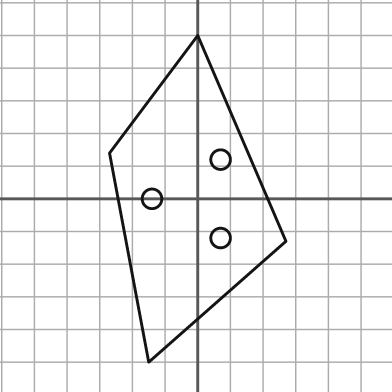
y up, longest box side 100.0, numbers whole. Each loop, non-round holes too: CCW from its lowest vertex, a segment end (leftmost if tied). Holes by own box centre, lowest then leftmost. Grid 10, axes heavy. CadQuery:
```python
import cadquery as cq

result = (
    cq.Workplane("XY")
    .moveTo(-15.0, -50.0)
    .lineTo(27.0, -13.0)
    .lineTo(0.0, 50.0)
    .lineTo(-27.0, 14.0)
    .close()
    .moveTo(7.0, -12.0)
    .circle(3.0)
    .moveTo(-14.0, 0.0)
    .circle(3.0)
    .moveTo(7.0, 12.0)
    .circle(3.0)
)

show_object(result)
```